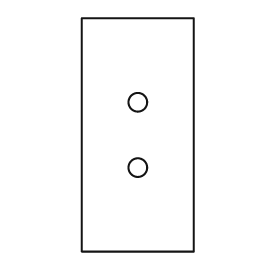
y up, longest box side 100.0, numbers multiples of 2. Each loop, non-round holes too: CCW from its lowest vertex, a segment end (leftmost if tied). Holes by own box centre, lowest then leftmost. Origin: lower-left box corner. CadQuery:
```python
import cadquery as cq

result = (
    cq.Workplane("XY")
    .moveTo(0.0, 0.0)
    .lineTo(48.0, 0.0)
    .lineTo(48.0, 100.0)
    .lineTo(0.0, 100.0)
    .close()
    .moveTo(24.0, 36.0)
    .circle(4.0)
    .moveTo(24.0, 64.0)
    .circle(4.0)
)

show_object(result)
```